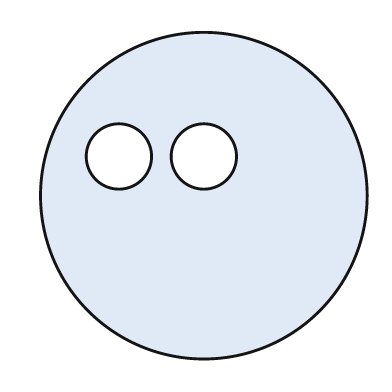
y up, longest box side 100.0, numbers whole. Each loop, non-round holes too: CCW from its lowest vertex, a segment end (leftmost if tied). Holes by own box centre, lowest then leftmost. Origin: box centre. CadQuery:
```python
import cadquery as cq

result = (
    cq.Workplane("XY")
    .moveTo(0.0, 0.0)
    .circle(50.0)
    .moveTo(-26.0, 12.0)
    .circle(10.0)
    .moveTo(0.0, 12.0)
    .circle(10.0)
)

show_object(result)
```